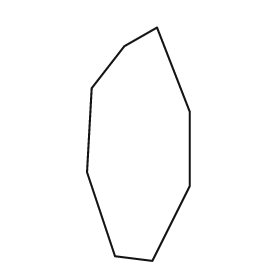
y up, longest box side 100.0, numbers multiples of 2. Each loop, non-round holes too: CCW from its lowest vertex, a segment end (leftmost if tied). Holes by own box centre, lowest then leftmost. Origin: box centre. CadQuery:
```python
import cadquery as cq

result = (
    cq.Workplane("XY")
    .moveTo(6.0, -50.0)
    .lineTo(22.0, -18.0)
    .lineTo(22.0, 14.0)
    .lineTo(8.0, 50.0)
    .lineTo(-6.0, 42.0)
    .lineTo(-20.0, 24.0)
    .lineTo(-22.0, -12.0)
    .lineTo(-10.0, -48.0)
    .close()
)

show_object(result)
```